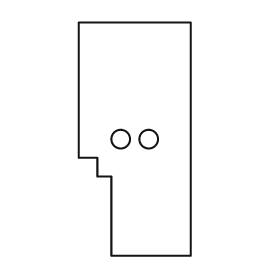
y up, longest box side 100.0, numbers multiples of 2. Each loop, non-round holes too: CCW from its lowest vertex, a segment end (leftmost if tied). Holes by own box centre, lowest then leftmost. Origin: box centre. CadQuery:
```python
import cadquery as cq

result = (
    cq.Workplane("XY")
    .moveTo(-10.0, -50.0)
    .lineTo(24.0, -50.0)
    .lineTo(24.0, 50.0)
    .lineTo(-24.0, 50.0)
    .lineTo(-24.0, -8.0)
    .lineTo(-16.0, -8.0)
    .lineTo(-16.0, -16.0)
    .lineTo(-10.0, -16.0)
    .close()
    .moveTo(-6.0, 0.0)
    .circle(4.0)
    .moveTo(6.0, 0.0)
    .circle(4.0)
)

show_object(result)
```